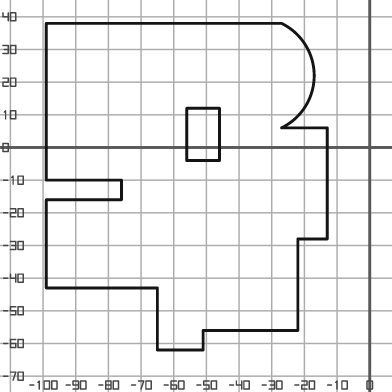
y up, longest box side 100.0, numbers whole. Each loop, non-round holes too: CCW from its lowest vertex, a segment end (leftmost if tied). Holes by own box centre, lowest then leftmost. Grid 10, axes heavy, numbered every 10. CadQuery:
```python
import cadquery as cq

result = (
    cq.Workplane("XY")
    .moveTo(-65.0, -62.0)
    .lineTo(-51.0, -62.0)
    .lineTo(-51.0, -56.0)
    .lineTo(-22.0, -56.0)
    .lineTo(-22.0, -28.0)
    .lineTo(-13.0, -28.0)
    .lineTo(-13.0, 6.0)
    .lineTo(-27.0, 6.0)
    .threePointArc((-17.0, 22.0), (-27.0, 38.0))
    .lineTo(-99.0, 38.0)
    .lineTo(-99.0, -10.0)
    .lineTo(-76.0, -10.0)
    .lineTo(-76.0, -16.0)
    .lineTo(-99.0, -16.0)
    .lineTo(-99.0, -43.0)
    .lineTo(-65.0, -43.0)
    .close()
    .moveTo(-56.0, -4.0)
    .lineTo(-46.0, -4.0)
    .lineTo(-46.0, 12.0)
    .lineTo(-56.0, 12.0)
    .close()
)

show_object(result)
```